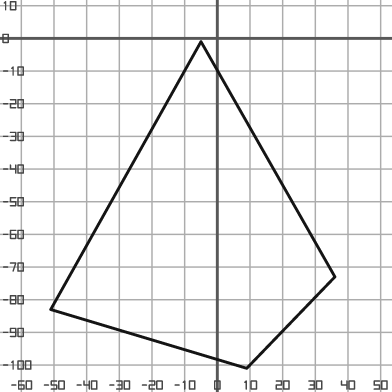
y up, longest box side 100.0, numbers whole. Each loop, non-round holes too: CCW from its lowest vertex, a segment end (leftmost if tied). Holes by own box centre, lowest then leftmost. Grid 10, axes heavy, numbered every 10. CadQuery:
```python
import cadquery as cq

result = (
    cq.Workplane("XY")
    .moveTo(9.0, -101.0)
    .lineTo(36.0, -73.0)
    .lineTo(-5.0, -1.0)
    .lineTo(-51.0, -83.0)
    .close()
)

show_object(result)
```